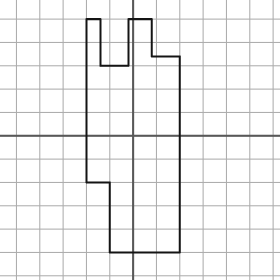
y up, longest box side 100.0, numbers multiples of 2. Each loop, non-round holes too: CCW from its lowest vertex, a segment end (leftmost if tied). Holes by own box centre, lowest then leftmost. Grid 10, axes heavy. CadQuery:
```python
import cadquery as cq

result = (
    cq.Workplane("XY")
    .moveTo(-10.0, -50.0)
    .lineTo(20.0, -50.0)
    .lineTo(20.0, 34.0)
    .lineTo(8.0, 34.0)
    .lineTo(8.0, 50.0)
    .lineTo(-2.0, 50.0)
    .lineTo(-2.0, 30.0)
    .lineTo(-14.0, 30.0)
    .lineTo(-14.0, 50.0)
    .lineTo(-20.0, 50.0)
    .lineTo(-20.0, -20.0)
    .lineTo(-10.0, -20.0)
    .close()
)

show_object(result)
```